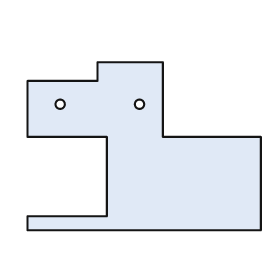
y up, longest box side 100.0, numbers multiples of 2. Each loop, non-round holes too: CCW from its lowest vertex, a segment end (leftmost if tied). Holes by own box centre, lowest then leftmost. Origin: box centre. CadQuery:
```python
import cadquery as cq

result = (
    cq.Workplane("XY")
    .moveTo(-50.0, -36.0)
    .lineTo(50.0, -36.0)
    .lineTo(50.0, 4.0)
    .lineTo(8.0, 4.0)
    .lineTo(8.0, 36.0)
    .lineTo(-20.0, 36.0)
    .lineTo(-20.0, 28.0)
    .lineTo(-50.0, 28.0)
    .lineTo(-50.0, 4.0)
    .lineTo(-16.0, 4.0)
    .lineTo(-16.0, -30.0)
    .lineTo(-50.0, -30.0)
    .close()
    .moveTo(-36.0, 18.0)
    .circle(2.0)
    .moveTo(-2.0, 18.0)
    .circle(2.0)
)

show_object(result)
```